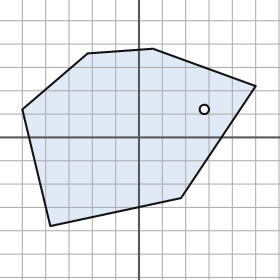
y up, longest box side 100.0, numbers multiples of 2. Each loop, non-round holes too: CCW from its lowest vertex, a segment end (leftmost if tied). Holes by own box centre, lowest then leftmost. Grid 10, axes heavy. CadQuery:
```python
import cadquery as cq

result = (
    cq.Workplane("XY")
    .moveTo(-38.0, -38.0)
    .lineTo(18.0, -26.0)
    .lineTo(50.0, 22.0)
    .lineTo(6.0, 38.0)
    .lineTo(-22.0, 36.0)
    .lineTo(-50.0, 12.0)
    .close()
    .moveTo(28.0, 12.0)
    .circle(2.0)
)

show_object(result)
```